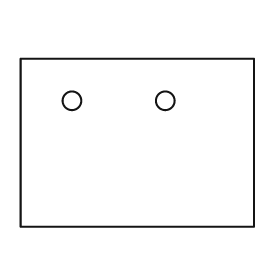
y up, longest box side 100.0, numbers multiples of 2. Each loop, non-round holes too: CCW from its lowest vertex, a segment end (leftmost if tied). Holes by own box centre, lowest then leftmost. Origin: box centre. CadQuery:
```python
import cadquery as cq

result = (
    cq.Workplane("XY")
    .moveTo(-50.0, -36.0)
    .lineTo(50.0, -36.0)
    .lineTo(50.0, 36.0)
    .lineTo(-50.0, 36.0)
    .close()
    .moveTo(-28.0, 18.0)
    .circle(4.0)
    .moveTo(12.0, 18.0)
    .circle(4.0)
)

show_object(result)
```